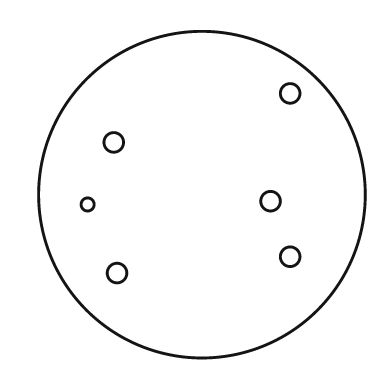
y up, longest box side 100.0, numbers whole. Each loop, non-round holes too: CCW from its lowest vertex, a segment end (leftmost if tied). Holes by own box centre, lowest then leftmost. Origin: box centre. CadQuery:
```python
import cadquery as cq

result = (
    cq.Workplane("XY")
    .moveTo(0.0, 0.0)
    .circle(50.0)
    .moveTo(-26.0, -24.0)
    .circle(3.0)
    .moveTo(27.0, -19.0)
    .circle(3.0)
    .moveTo(-35.0, -3.0)
    .circle(2.0)
    .moveTo(21.0, -2.0)
    .circle(3.0)
    .moveTo(-27.0, 16.0)
    .circle(3.0)
    .moveTo(27.0, 31.0)
    .circle(3.0)
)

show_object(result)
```